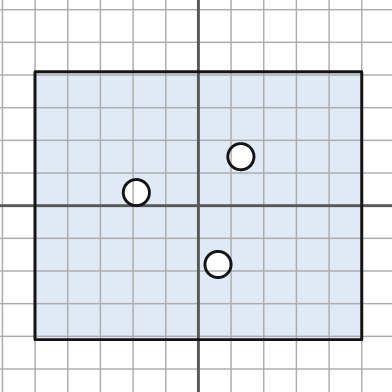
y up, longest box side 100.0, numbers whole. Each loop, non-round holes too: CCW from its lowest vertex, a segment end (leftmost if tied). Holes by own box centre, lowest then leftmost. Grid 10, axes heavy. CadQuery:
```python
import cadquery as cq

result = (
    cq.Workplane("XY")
    .moveTo(-50.0, -41.0)
    .lineTo(50.0, -41.0)
    .lineTo(50.0, 41.0)
    .lineTo(-50.0, 41.0)
    .close()
    .moveTo(6.0, -18.0)
    .circle(4.0)
    .moveTo(-19.0, 4.0)
    .circle(4.0)
    .moveTo(13.0, 15.0)
    .circle(4.0)
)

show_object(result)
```